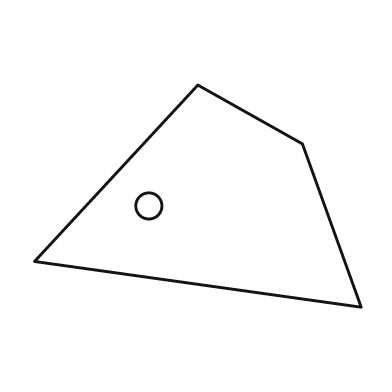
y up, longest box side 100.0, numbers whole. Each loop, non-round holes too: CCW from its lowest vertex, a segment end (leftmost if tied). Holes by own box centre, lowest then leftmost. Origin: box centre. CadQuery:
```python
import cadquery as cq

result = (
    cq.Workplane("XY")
    .moveTo(50.0, -34.0)
    .lineTo(32.0, 16.0)
    .lineTo(0.0, 34.0)
    .lineTo(-50.0, -20.0)
    .close()
    .moveTo(-15.0, -3.0)
    .circle(4.0)
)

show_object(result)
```